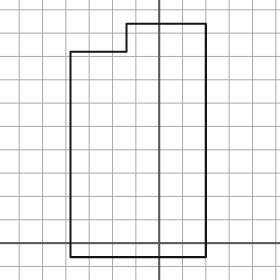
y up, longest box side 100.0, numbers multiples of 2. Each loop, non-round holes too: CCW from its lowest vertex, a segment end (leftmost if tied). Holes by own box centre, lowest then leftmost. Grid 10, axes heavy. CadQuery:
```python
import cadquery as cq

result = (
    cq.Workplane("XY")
    .moveTo(-38.0, -6.0)
    .lineTo(20.0, -6.0)
    .lineTo(20.0, 94.0)
    .lineTo(-14.0, 94.0)
    .lineTo(-14.0, 82.0)
    .lineTo(-38.0, 82.0)
    .close()
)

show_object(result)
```